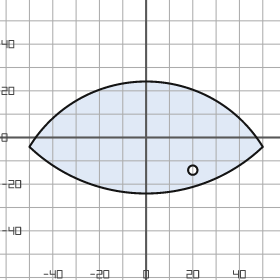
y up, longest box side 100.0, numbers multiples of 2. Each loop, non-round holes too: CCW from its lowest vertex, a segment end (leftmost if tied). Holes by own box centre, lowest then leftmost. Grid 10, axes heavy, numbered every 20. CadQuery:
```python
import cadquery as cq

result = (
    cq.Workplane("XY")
    .moveTo(-50.0, -4.0)
    .threePointArc((0.0, -24.0), (50.0, -4.0))
    .threePointArc((0.0, 24.0), (-50.0, -4.0))
    .close()
    .moveTo(20.0, -14.0)
    .circle(2.0)
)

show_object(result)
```